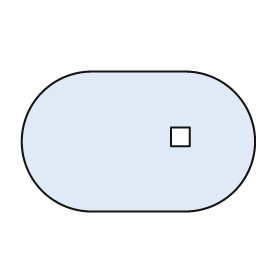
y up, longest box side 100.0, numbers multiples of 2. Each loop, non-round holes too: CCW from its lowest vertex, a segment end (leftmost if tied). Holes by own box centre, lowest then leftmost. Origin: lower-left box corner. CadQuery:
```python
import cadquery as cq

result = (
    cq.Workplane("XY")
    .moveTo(30.0, 0.0)
    .lineTo(70.0, 0.0)
    .threePointArc((100.0, 30.0), (70.0, 60.0))
    .lineTo(30.0, 60.0)
    .threePointArc((0.0, 30.0), (30.0, 0.0))
    .close()
    .moveTo(64.0, 28.0)
    .lineTo(72.0, 28.0)
    .lineTo(72.0, 36.0)
    .lineTo(64.0, 36.0)
    .close()
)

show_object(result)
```